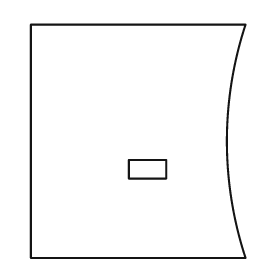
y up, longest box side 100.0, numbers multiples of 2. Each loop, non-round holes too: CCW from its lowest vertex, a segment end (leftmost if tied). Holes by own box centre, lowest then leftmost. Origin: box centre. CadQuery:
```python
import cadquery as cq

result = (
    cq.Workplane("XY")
    .moveTo(-46.0, -50.0)
    .lineTo(46.0, -50.0)
    .threePointArc((38.0, 0.0), (46.0, 50.0))
    .lineTo(-46.0, 50.0)
    .close()
    .moveTo(-4.0, -16.0)
    .lineTo(12.0, -16.0)
    .lineTo(12.0, -8.0)
    .lineTo(-4.0, -8.0)
    .close()
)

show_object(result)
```